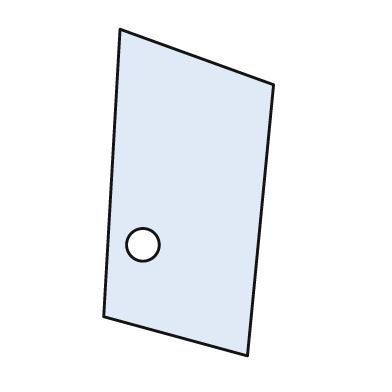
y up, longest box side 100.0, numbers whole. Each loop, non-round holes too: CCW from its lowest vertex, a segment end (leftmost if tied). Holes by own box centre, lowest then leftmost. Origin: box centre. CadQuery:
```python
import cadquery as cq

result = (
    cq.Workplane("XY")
    .moveTo(18.0, -50.0)
    .lineTo(26.0, 33.0)
    .lineTo(-21.0, 50.0)
    .lineTo(-26.0, -38.0)
    .close()
    .moveTo(-14.0, -16.0)
    .circle(5.0)
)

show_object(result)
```